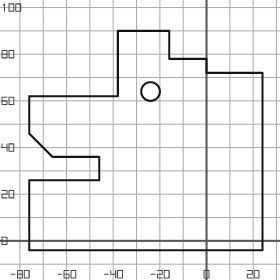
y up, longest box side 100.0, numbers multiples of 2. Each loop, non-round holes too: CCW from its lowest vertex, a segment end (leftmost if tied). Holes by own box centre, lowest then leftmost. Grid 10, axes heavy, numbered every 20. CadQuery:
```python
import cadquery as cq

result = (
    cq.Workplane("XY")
    .moveTo(-76.0, -4.0)
    .lineTo(24.0, -4.0)
    .lineTo(24.0, 72.0)
    .lineTo(0.0, 72.0)
    .lineTo(0.0, 78.0)
    .lineTo(-16.0, 78.0)
    .lineTo(-16.0, 90.0)
    .lineTo(-38.0, 90.0)
    .lineTo(-38.0, 62.0)
    .lineTo(-76.0, 62.0)
    .lineTo(-76.0, 46.0)
    .lineTo(-66.0, 36.0)
    .lineTo(-46.0, 36.0)
    .lineTo(-46.0, 26.0)
    .lineTo(-76.0, 26.0)
    .close()
    .moveTo(-24.0, 64.0)
    .circle(4.0)
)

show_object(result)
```